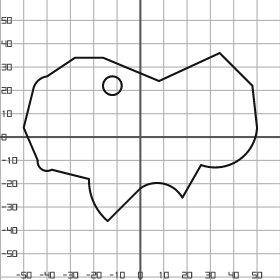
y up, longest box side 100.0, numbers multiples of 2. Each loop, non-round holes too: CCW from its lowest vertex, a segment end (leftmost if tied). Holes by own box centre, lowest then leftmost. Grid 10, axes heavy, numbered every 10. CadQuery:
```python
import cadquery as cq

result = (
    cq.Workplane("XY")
    .moveTo(-14.0, -36.0)
    .lineTo(0.0, -22.0)
    .threePointArc((10.0, -20.0), (18.0, -26.0))
    .lineTo(26.0, -12.0)
    .threePointArc((42.0, -10.0), (50.0, 4.0))
    .lineTo(48.0, 22.0)
    .lineTo(34.0, 36.0)
    .lineTo(8.0, 24.0)
    .lineTo(-16.0, 34.0)
    .lineTo(-28.0, 34.0)
    .lineTo(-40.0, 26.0)
    .threePointArc((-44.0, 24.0), (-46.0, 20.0))
    .lineTo(-50.0, 4.0)
    .lineTo(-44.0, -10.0)
    .threePointArc((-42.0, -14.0), (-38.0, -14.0))
    .lineTo(-22.0, -18.0)
    .threePointArc((-20.0, -28.0), (-14.0, -36.0))
    .close()
    .moveTo(-12.0, 22.0)
    .circle(4.0)
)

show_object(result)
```